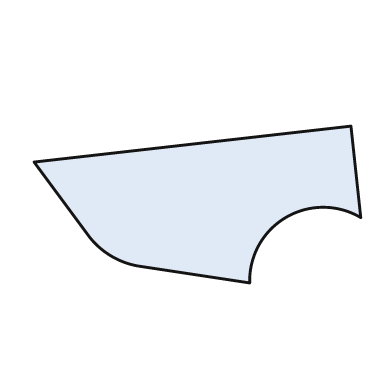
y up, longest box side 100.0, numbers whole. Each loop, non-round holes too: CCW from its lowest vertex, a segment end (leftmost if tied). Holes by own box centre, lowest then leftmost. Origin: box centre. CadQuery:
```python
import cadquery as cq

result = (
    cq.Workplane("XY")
    .moveTo(16.0, -24.0)
    .threePointArc((27.0, -4.0), (50.0, -4.0))
    .lineTo(47.0, 24.0)
    .lineTo(-50.0, 13.0)
    .lineTo(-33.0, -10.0)
    .threePointArc((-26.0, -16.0), (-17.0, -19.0))
    .close()
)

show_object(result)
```